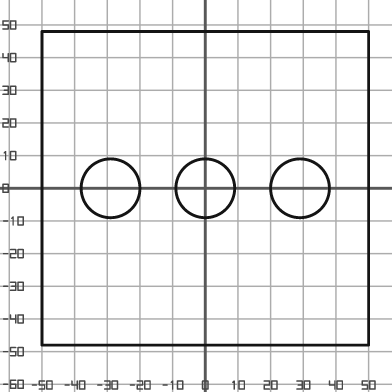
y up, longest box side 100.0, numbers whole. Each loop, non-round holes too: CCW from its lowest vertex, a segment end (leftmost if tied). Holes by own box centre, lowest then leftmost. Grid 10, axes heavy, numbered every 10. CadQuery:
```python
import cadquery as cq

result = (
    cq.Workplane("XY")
    .moveTo(-50.0, -48.0)
    .lineTo(50.0, -48.0)
    .lineTo(50.0, 48.0)
    .lineTo(-50.0, 48.0)
    .close()
    .moveTo(-29.0, 0.0)
    .circle(9.0)
    .moveTo(0.0, 0.0)
    .circle(9.0)
    .moveTo(29.0, 0.0)
    .circle(9.0)
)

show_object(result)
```